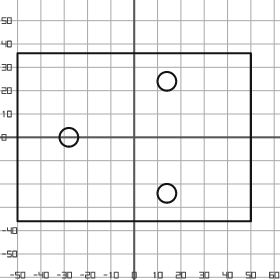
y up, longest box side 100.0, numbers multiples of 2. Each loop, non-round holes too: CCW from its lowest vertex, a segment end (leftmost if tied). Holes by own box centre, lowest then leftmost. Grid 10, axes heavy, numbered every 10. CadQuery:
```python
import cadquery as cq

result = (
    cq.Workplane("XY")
    .moveTo(-50.0, -36.0)
    .lineTo(50.0, -36.0)
    .lineTo(50.0, 36.0)
    .lineTo(-50.0, 36.0)
    .close()
    .moveTo(14.0, -24.0)
    .circle(4.0)
    .moveTo(-28.0, 0.0)
    .circle(4.0)
    .moveTo(14.0, 24.0)
    .circle(4.0)
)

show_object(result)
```